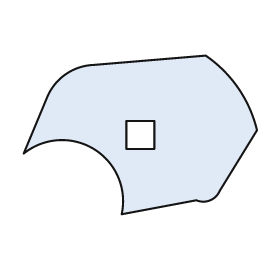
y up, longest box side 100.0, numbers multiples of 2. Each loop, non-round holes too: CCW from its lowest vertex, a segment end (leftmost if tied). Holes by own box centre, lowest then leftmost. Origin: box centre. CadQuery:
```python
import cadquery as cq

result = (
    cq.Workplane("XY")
    .moveTo(-8.0, -34.0)
    .lineTo(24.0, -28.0)
    .threePointArc((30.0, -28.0), (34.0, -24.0))
    .lineTo(50.0, 2.0)
    .threePointArc((42.0, 20.0), (28.0, 34.0))
    .lineTo(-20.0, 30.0)
    .threePointArc((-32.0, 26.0), (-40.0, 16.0))
    .lineTo(-50.0, -8.0)
    .threePointArc((-20.0, -6.0), (-8.0, -34.0))
    .close()
    .moveTo(-6.0, -6.0)
    .lineTo(6.0, -6.0)
    .lineTo(6.0, 6.0)
    .lineTo(-6.0, 6.0)
    .close()
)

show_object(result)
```